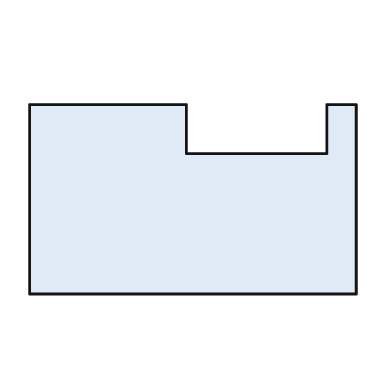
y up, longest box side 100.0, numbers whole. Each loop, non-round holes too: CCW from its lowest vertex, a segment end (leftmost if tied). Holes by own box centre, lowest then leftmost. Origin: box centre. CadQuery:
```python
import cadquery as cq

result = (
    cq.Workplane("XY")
    .moveTo(-50.0, -29.0)
    .lineTo(50.0, -29.0)
    .lineTo(50.0, 29.0)
    .lineTo(41.0, 29.0)
    .lineTo(41.0, 14.0)
    .lineTo(-2.0, 14.0)
    .lineTo(-2.0, 29.0)
    .lineTo(-50.0, 29.0)
    .close()
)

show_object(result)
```